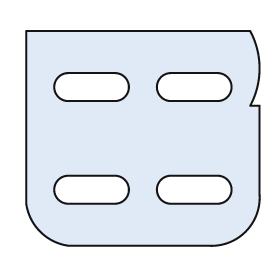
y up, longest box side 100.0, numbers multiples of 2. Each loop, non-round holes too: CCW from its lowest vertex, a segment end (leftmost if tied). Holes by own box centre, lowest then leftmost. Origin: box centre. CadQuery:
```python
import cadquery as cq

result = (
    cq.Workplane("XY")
    .moveTo(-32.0, -46.0)
    .lineTo(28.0, -46.0)
    .threePointArc((44.0, -40.0), (50.0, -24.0))
    .lineTo(50.0, 14.0)
    .lineTo(46.0, 14.0)
    .threePointArc((50.0, 30.0), (46.0, 46.0))
    .lineTo(-50.0, 46.0)
    .lineTo(-50.0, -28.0)
    .threePointArc((-44.0, -40.0), (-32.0, -46.0))
    .close()
    .moveTo(-32.0, -28.0)
    .lineTo(-12.0, -28.0)
    .threePointArc((-6.0, -22.0), (-12.0, -16.0))
    .lineTo(-32.0, -16.0)
    .threePointArc((-38.0, -22.0), (-32.0, -28.0))
    .close()
    .moveTo(12.0, -28.0)
    .lineTo(32.0, -28.0)
    .threePointArc((38.0, -22.0), (32.0, -16.0))
    .lineTo(12.0, -16.0)
    .threePointArc((6.0, -22.0), (12.0, -28.0))
    .close()
    .moveTo(-32.0, 16.0)
    .lineTo(-12.0, 16.0)
    .threePointArc((-6.0, 22.0), (-12.0, 28.0))
    .lineTo(-32.0, 28.0)
    .threePointArc((-38.0, 22.0), (-32.0, 16.0))
    .close()
    .moveTo(12.0, 16.0)
    .lineTo(32.0, 16.0)
    .threePointArc((38.0, 22.0), (32.0, 28.0))
    .lineTo(12.0, 28.0)
    .threePointArc((6.0, 22.0), (12.0, 16.0))
    .close()
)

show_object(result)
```